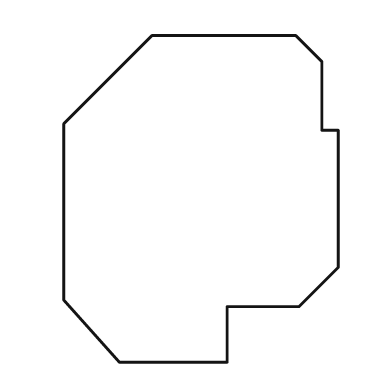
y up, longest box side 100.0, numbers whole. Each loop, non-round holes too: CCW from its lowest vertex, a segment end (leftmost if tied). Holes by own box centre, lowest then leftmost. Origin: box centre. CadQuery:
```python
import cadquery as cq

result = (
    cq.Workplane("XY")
    .moveTo(-25.0, -50.0)
    .lineTo(8.0, -50.0)
    .lineTo(8.0, -33.0)
    .lineTo(30.0, -33.0)
    .lineTo(42.0, -21.0)
    .lineTo(42.0, 21.0)
    .lineTo(37.0, 21.0)
    .lineTo(37.0, 42.0)
    .lineTo(29.0, 50.0)
    .lineTo(-15.0, 50.0)
    .lineTo(-42.0, 23.0)
    .lineTo(-42.0, -31.0)
    .close()
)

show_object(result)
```